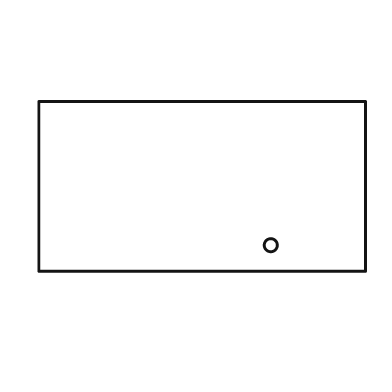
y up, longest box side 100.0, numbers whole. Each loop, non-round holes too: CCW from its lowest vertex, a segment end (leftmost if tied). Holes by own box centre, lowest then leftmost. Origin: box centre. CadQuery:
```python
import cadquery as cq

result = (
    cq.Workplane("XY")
    .moveTo(-50.0, -26.0)
    .lineTo(50.0, -26.0)
    .lineTo(50.0, 26.0)
    .lineTo(-50.0, 26.0)
    .close()
    .moveTo(21.0, -18.0)
    .circle(2.0)
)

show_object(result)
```